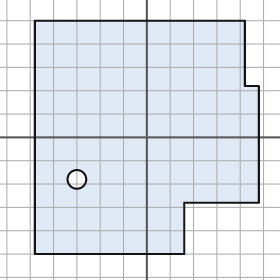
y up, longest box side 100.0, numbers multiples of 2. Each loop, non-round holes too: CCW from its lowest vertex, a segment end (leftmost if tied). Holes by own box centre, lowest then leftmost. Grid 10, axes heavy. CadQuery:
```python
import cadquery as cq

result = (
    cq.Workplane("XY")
    .moveTo(-48.0, -50.0)
    .lineTo(16.0, -50.0)
    .lineTo(16.0, -28.0)
    .lineTo(48.0, -28.0)
    .lineTo(48.0, 22.0)
    .lineTo(42.0, 22.0)
    .lineTo(42.0, 50.0)
    .lineTo(-48.0, 50.0)
    .close()
    .moveTo(-30.0, -18.0)
    .circle(4.0)
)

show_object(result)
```